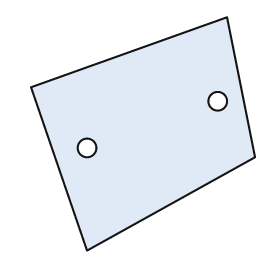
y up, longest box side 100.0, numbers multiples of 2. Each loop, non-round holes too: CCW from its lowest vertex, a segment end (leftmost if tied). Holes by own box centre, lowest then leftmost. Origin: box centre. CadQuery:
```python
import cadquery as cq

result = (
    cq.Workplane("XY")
    .moveTo(-24.0, -50.0)
    .lineTo(48.0, -10.0)
    .lineTo(36.0, 50.0)
    .lineTo(-48.0, 20.0)
    .close()
    .moveTo(-24.0, -6.0)
    .circle(4.0)
    .moveTo(32.0, 14.0)
    .circle(4.0)
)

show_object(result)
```